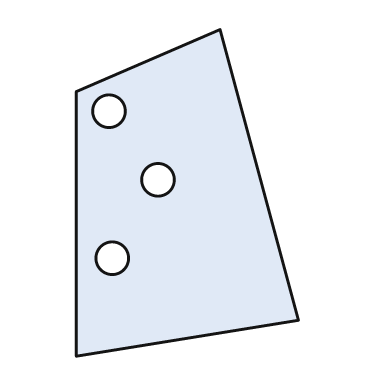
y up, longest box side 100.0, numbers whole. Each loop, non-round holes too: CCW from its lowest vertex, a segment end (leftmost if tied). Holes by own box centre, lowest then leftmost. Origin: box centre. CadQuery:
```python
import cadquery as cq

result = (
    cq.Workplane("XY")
    .moveTo(-34.0, -50.0)
    .lineTo(34.0, -39.0)
    .lineTo(10.0, 50.0)
    .lineTo(-34.0, 31.0)
    .close()
    .moveTo(-23.0, -20.0)
    .circle(5.0)
    .moveTo(-9.0, 4.0)
    .circle(5.0)
    .moveTo(-24.0, 25.0)
    .circle(5.0)
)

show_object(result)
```